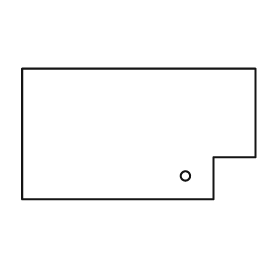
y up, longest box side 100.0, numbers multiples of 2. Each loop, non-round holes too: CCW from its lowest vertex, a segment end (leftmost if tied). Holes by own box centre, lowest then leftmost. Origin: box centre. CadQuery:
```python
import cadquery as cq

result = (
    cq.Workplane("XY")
    .moveTo(-50.0, -28.0)
    .lineTo(32.0, -28.0)
    .lineTo(32.0, -10.0)
    .lineTo(50.0, -10.0)
    .lineTo(50.0, 28.0)
    .lineTo(-50.0, 28.0)
    .close()
    .moveTo(20.0, -18.0)
    .circle(2.0)
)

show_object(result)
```